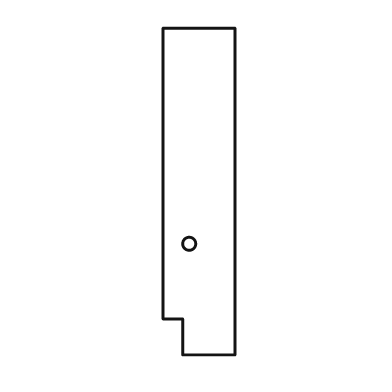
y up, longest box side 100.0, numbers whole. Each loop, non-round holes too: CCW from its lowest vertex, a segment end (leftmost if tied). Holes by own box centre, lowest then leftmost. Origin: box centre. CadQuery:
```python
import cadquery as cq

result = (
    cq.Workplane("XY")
    .moveTo(-5.0, -50.0)
    .lineTo(11.0, -50.0)
    .lineTo(11.0, 50.0)
    .lineTo(-11.0, 50.0)
    .lineTo(-11.0, -39.0)
    .lineTo(-5.0, -39.0)
    .close()
    .moveTo(-3.0, -16.0)
    .circle(2.0)
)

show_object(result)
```